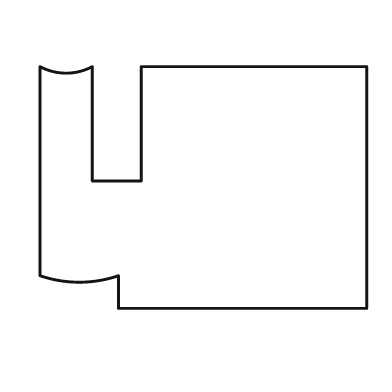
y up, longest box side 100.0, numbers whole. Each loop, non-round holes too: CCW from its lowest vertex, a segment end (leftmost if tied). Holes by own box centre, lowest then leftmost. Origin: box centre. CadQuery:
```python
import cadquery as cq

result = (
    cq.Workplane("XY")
    .moveTo(-26.0, -37.0)
    .lineTo(50.0, -37.0)
    .lineTo(50.0, 37.0)
    .lineTo(-19.0, 37.0)
    .lineTo(-19.0, 2.0)
    .lineTo(-34.0, 2.0)
    .lineTo(-34.0, 37.0)
    .threePointArc((-42.0, 35.0), (-50.0, 37.0))
    .lineTo(-50.0, -27.0)
    .threePointArc((-38.0, -29.0), (-26.0, -27.0))
    .close()
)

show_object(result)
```